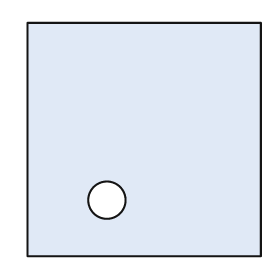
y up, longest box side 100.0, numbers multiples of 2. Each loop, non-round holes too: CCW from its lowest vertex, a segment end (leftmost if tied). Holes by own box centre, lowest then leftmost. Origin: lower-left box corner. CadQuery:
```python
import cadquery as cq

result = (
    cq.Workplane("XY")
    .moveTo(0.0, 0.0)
    .lineTo(100.0, 0.0)
    .lineTo(100.0, 100.0)
    .lineTo(0.0, 100.0)
    .close()
    .moveTo(34.0, 24.0)
    .circle(8.0)
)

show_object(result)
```